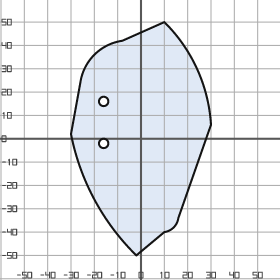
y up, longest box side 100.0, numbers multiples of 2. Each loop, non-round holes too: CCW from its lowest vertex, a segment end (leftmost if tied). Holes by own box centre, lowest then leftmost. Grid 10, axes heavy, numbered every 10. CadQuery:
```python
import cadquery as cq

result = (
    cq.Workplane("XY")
    .moveTo(-2.0, -50.0)
    .lineTo(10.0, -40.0)
    .threePointArc((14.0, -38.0), (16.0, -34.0))
    .lineTo(30.0, 6.0)
    .threePointArc((24.0, 30.0), (10.0, 50.0))
    .lineTo(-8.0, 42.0)
    .threePointArc((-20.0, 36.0), (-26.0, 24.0))
    .lineTo(-30.0, 2.0)
    .threePointArc((-20.0, -26.0), (-2.0, -50.0))
    .close()
    .moveTo(-16.0, -2.0)
    .circle(2.0)
    .moveTo(-16.0, 16.0)
    .circle(2.0)
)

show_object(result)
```